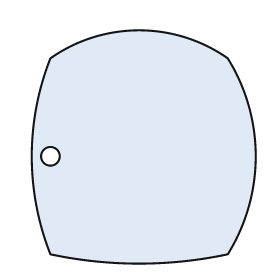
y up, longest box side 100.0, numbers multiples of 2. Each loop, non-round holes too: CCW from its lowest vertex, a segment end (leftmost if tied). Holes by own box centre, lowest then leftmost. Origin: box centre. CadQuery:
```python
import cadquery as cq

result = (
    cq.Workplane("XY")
    .moveTo(-40.0, -46.0)
    .threePointArc((-2.0, -50.0), (36.0, -46.0))
    .threePointArc((48.0, -4.0), (36.0, 38.0))
    .threePointArc((-2.0, 50.0), (-40.0, 38.0))
    .threePointArc((-48.0, -4.0), (-40.0, -46.0))
    .close()
    .moveTo(-40.0, -4.0)
    .circle(4.0)
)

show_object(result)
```